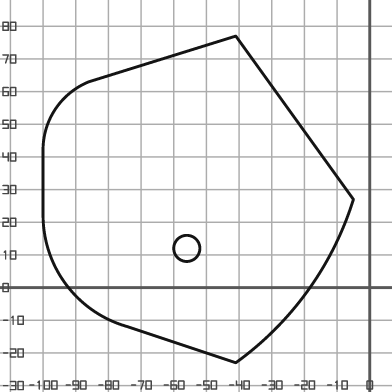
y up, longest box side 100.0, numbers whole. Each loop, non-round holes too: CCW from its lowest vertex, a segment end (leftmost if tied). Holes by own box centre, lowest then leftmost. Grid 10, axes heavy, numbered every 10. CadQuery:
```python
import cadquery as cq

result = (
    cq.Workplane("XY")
    .moveTo(-41.0, -23.0)
    .threePointArc((-19.0, -1.0), (-5.0, 27.0))
    .lineTo(-41.0, 77.0)
    .lineTo(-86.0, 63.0)
    .threePointArc((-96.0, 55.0), (-100.0, 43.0))
    .lineTo(-100.0, 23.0)
    .threePointArc((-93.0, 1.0), (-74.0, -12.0))
    .close()
    .moveTo(-56.0, 12.0)
    .circle(4.0)
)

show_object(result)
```